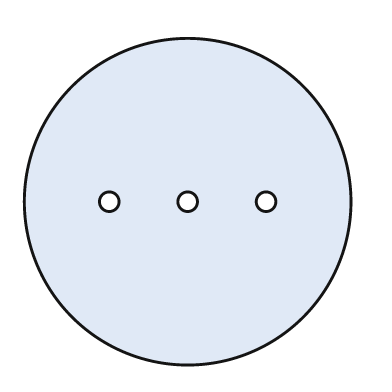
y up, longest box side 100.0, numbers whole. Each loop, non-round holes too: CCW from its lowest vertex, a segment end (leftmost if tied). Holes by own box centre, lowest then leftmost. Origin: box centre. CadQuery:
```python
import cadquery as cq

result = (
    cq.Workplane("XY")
    .moveTo(0.0, 0.0)
    .circle(50.0)
    .moveTo(-24.0, 0.0)
    .circle(3.0)
    .moveTo(0.0, 0.0)
    .circle(3.0)
    .moveTo(24.0, 0.0)
    .circle(3.0)
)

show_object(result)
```